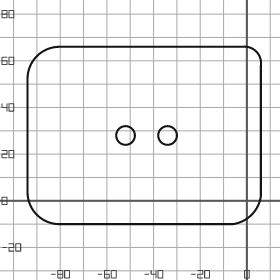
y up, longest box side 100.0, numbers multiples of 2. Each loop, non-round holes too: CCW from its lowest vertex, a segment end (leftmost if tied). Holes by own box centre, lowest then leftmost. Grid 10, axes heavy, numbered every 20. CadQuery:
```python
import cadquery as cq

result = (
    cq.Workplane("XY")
    .moveTo(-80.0, -10.0)
    .lineTo(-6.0, -10.0)
    .threePointArc((2.0, -6.0), (6.0, 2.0))
    .lineTo(6.0, 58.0)
    .threePointArc((4.0, 64.0), (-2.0, 66.0))
    .lineTo(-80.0, 66.0)
    .threePointArc((-90.0, 62.0), (-94.0, 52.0))
    .lineTo(-94.0, 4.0)
    .threePointArc((-90.0, -6.0), (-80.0, -10.0))
    .close()
    .moveTo(-52.0, 28.0)
    .circle(4.0)
    .moveTo(-34.0, 28.0)
    .circle(4.0)
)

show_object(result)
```